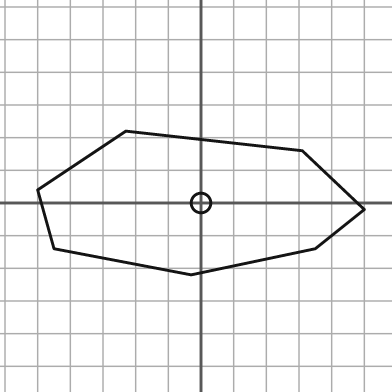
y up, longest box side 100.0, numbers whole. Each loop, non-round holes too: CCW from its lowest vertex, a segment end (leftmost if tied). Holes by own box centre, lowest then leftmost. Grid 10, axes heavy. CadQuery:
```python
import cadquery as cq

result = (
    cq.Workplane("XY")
    .moveTo(-3.0, -22.0)
    .lineTo(35.0, -14.0)
    .lineTo(50.0, -2.0)
    .lineTo(31.0, 16.0)
    .lineTo(-23.0, 22.0)
    .lineTo(-50.0, 4.0)
    .lineTo(-45.0, -14.0)
    .close()
    .moveTo(0.0, 0.0)
    .circle(3.0)
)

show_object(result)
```